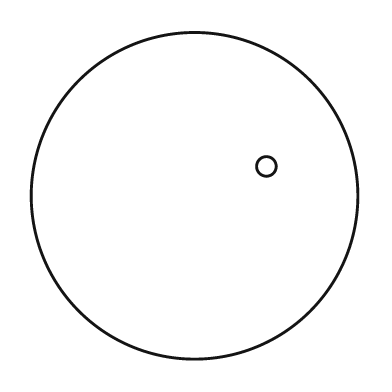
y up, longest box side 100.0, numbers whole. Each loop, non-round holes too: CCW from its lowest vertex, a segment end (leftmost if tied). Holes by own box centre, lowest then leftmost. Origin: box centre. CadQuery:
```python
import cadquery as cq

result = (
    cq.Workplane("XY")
    .moveTo(0.0, 0.0)
    .circle(50.0)
    .moveTo(22.0, 9.0)
    .circle(3.0)
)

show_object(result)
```